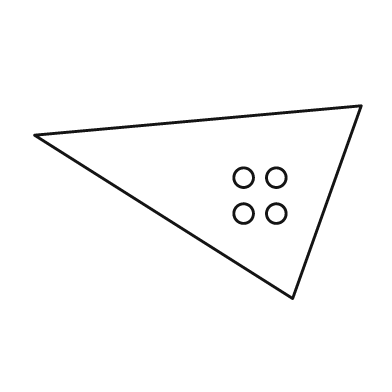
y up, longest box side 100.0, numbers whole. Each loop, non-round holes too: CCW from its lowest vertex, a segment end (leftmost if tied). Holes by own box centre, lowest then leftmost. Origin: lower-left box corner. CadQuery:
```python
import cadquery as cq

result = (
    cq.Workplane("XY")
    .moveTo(79.0, 0.0)
    .lineTo(100.0, 59.0)
    .lineTo(0.0, 50.0)
    .close()
    .moveTo(64.0, 26.0)
    .circle(3.0)
    .moveTo(74.0, 26.0)
    .circle(3.0)
    .moveTo(64.0, 37.0)
    .circle(3.0)
    .moveTo(74.0, 37.0)
    .circle(3.0)
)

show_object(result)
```